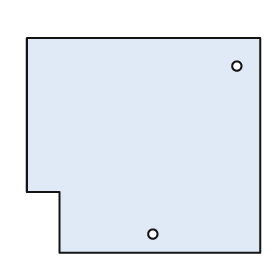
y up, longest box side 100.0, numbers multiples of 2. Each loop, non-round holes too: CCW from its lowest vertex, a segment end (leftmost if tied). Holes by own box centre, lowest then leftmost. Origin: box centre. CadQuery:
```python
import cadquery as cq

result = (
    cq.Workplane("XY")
    .moveTo(-36.0, -46.0)
    .lineTo(50.0, -46.0)
    .lineTo(50.0, 46.0)
    .lineTo(-50.0, 46.0)
    .lineTo(-50.0, -20.0)
    .lineTo(-36.0, -20.0)
    .close()
    .moveTo(4.0, -38.0)
    .circle(2.0)
    .moveTo(40.0, 34.0)
    .circle(2.0)
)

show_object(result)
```